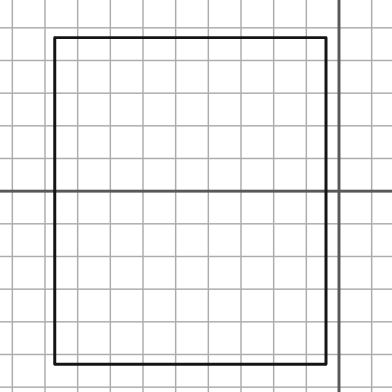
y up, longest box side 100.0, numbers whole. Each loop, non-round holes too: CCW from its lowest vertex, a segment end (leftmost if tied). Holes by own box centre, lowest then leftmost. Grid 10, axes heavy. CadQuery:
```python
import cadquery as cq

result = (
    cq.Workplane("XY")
    .moveTo(-87.0, -53.0)
    .lineTo(-4.0, -53.0)
    .lineTo(-4.0, 47.0)
    .lineTo(-87.0, 47.0)
    .close()
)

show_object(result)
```